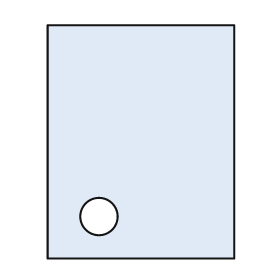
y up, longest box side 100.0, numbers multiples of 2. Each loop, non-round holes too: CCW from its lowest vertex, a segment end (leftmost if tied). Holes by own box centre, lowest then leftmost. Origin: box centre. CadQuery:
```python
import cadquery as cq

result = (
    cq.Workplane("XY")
    .moveTo(-40.0, -50.0)
    .lineTo(40.0, -50.0)
    .lineTo(40.0, 50.0)
    .lineTo(-40.0, 50.0)
    .close()
    .moveTo(-18.0, -32.0)
    .circle(8.0)
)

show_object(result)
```